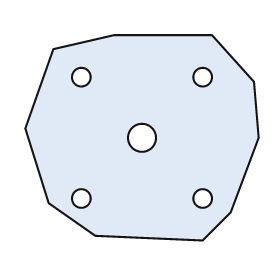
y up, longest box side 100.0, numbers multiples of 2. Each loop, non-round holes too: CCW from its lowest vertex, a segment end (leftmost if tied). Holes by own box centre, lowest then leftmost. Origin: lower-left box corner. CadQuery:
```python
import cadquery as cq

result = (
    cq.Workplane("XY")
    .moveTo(76.0, 0.0)
    .lineTo(88.0, 12.0)
    .lineTo(100.0, 44.0)
    .lineTo(98.0, 68.0)
    .lineTo(80.0, 88.0)
    .lineTo(38.0, 88.0)
    .lineTo(12.0, 82.0)
    .lineTo(0.0, 48.0)
    .lineTo(10.0, 16.0)
    .lineTo(30.0, 2.0)
    .close()
    .moveTo(24.0, 18.0)
    .circle(4.0)
    .moveTo(76.0, 18.0)
    .circle(4.0)
    .moveTo(50.0, 44.0)
    .circle(6.0)
    .moveTo(24.0, 70.0)
    .circle(4.0)
    .moveTo(76.0, 70.0)
    .circle(4.0)
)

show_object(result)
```